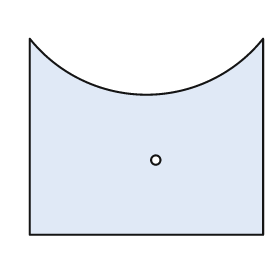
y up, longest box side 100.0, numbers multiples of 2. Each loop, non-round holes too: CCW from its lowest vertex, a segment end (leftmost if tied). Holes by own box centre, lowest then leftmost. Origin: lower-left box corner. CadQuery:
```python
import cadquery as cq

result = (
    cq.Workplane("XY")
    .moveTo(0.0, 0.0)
    .lineTo(100.0, 0.0)
    .lineTo(100.0, 84.0)
    .threePointArc((50.0, 60.0), (0.0, 84.0))
    .close()
    .moveTo(54.0, 32.0)
    .circle(2.0)
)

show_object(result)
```